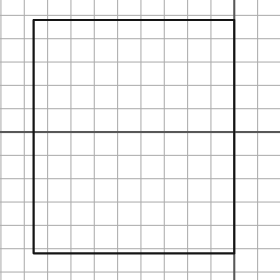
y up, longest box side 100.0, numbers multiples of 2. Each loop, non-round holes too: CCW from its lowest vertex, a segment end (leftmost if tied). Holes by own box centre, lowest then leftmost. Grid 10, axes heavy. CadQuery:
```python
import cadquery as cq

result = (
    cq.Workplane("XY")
    .moveTo(-86.0, -52.0)
    .lineTo(0.0, -52.0)
    .lineTo(0.0, 48.0)
    .lineTo(-86.0, 48.0)
    .close()
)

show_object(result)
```